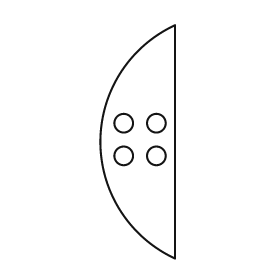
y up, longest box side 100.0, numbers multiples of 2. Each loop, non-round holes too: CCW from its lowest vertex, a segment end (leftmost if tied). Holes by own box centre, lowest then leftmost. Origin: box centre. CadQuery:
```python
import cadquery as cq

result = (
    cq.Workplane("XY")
    .moveTo(16.0, -50.0)
    .lineTo(16.0, 50.0)
    .threePointArc((-16.0, 0.0), (16.0, -50.0))
    .close()
    .moveTo(-6.0, -6.0)
    .circle(4.0)
    .moveTo(8.0, -6.0)
    .circle(4.0)
    .moveTo(-6.0, 8.0)
    .circle(4.0)
    .moveTo(8.0, 8.0)
    .circle(4.0)
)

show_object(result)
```